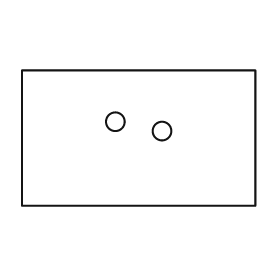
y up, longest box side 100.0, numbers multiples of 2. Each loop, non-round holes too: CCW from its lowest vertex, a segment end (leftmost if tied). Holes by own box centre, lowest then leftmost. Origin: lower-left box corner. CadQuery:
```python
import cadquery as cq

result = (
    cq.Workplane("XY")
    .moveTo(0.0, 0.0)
    .lineTo(100.0, 0.0)
    .lineTo(100.0, 58.0)
    .lineTo(0.0, 58.0)
    .close()
    .moveTo(60.0, 32.0)
    .circle(4.0)
    .moveTo(40.0, 36.0)
    .circle(4.0)
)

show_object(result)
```